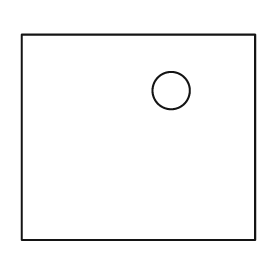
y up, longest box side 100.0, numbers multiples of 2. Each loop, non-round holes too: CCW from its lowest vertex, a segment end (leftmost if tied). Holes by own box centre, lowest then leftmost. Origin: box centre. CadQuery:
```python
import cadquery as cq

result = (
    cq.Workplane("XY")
    .moveTo(-50.0, -44.0)
    .lineTo(50.0, -44.0)
    .lineTo(50.0, 44.0)
    .lineTo(-50.0, 44.0)
    .close()
    .moveTo(14.0, 20.0)
    .circle(8.0)
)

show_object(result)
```